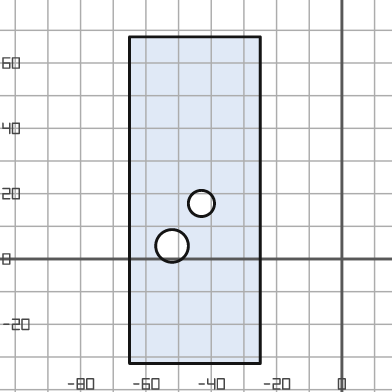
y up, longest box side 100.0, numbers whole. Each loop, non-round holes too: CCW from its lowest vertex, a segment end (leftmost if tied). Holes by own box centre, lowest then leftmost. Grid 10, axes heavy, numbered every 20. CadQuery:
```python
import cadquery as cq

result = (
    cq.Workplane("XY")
    .moveTo(-65.0, -32.0)
    .lineTo(-25.0, -32.0)
    .lineTo(-25.0, 68.0)
    .lineTo(-65.0, 68.0)
    .close()
    .moveTo(-52.0, 4.0)
    .circle(5.0)
    .moveTo(-43.0, 17.0)
    .circle(4.0)
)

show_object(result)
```